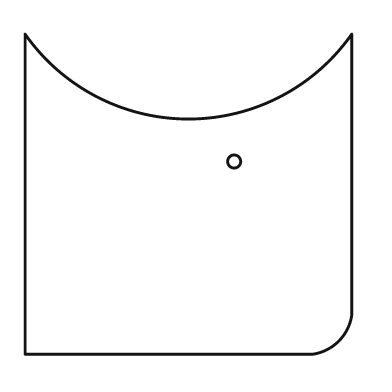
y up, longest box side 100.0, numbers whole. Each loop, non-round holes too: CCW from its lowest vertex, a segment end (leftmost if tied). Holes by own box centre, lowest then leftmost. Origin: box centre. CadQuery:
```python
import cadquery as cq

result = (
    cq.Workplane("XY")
    .moveTo(-50.0, -49.0)
    .lineTo(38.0, -49.0)
    .threePointArc((46.0, -45.0), (50.0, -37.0))
    .lineTo(50.0, 49.0)
    .threePointArc((0.0, 23.0), (-50.0, 49.0))
    .close()
    .moveTo(14.0, 10.0)
    .circle(2.0)
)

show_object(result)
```